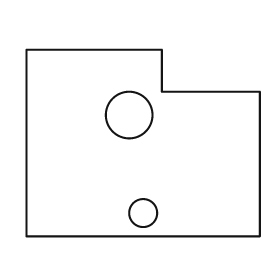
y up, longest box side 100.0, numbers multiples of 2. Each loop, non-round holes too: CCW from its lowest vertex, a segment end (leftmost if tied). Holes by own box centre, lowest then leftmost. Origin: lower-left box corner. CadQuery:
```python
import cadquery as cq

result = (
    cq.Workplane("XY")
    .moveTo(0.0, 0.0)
    .lineTo(100.0, 0.0)
    .lineTo(100.0, 62.0)
    .lineTo(58.0, 62.0)
    .lineTo(58.0, 80.0)
    .lineTo(0.0, 80.0)
    .close()
    .moveTo(50.0, 10.0)
    .circle(6.0)
    .moveTo(44.0, 52.0)
    .circle(10.0)
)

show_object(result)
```